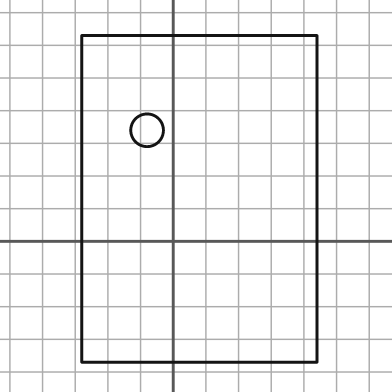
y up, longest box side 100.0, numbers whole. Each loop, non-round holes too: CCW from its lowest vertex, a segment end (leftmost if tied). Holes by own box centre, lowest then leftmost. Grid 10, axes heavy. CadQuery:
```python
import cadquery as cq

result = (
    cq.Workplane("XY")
    .moveTo(-28.0, -37.0)
    .lineTo(44.0, -37.0)
    .lineTo(44.0, 63.0)
    .lineTo(-28.0, 63.0)
    .close()
    .moveTo(-8.0, 34.0)
    .circle(5.0)
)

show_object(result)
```